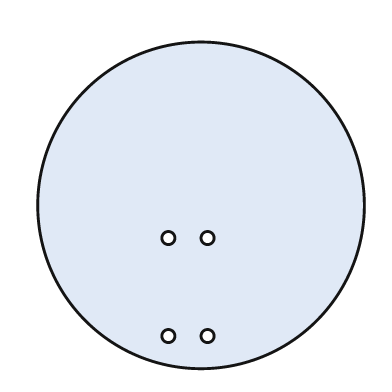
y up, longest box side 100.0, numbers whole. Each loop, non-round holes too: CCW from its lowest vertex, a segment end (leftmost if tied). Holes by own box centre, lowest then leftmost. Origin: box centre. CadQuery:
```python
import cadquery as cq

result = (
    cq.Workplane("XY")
    .moveTo(0.0, 0.0)
    .circle(50.0)
    .moveTo(-10.0, -40.0)
    .circle(2.0)
    .moveTo(2.0, -40.0)
    .circle(2.0)
    .moveTo(-10.0, -10.0)
    .circle(2.0)
    .moveTo(2.0, -10.0)
    .circle(2.0)
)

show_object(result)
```